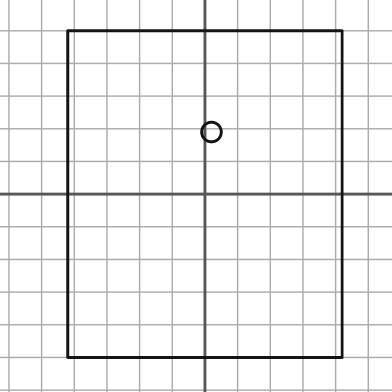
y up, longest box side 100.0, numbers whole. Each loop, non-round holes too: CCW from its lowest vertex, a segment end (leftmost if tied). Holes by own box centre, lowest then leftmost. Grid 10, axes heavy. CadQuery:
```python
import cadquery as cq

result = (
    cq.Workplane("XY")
    .moveTo(-42.0, -50.0)
    .lineTo(42.0, -50.0)
    .lineTo(42.0, 50.0)
    .lineTo(-42.0, 50.0)
    .close()
    .moveTo(2.0, 19.0)
    .circle(3.0)
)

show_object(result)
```